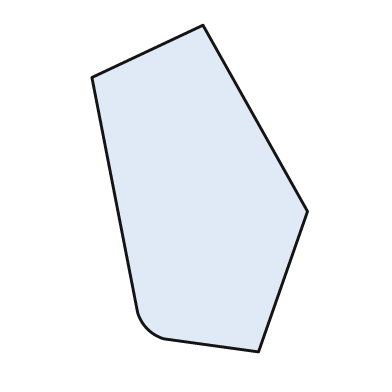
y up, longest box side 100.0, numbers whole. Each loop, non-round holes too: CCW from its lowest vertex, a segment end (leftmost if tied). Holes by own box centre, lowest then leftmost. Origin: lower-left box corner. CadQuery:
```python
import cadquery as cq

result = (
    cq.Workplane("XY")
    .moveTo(51.0, 0.0)
    .lineTo(66.0, 43.0)
    .lineTo(34.0, 100.0)
    .lineTo(0.0, 84.0)
    .lineTo(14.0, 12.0)
    .threePointArc((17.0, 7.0), (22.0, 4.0))
    .close()
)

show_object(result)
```